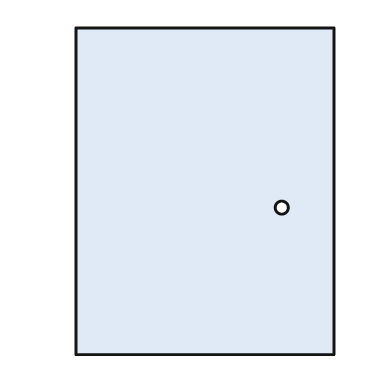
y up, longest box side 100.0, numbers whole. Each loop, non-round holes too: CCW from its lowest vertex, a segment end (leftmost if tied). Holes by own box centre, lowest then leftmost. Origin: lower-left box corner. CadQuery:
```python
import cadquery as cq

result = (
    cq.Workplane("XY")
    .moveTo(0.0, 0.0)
    .lineTo(79.0, 0.0)
    .lineTo(79.0, 100.0)
    .lineTo(0.0, 100.0)
    .close()
    .moveTo(63.0, 45.0)
    .circle(2.0)
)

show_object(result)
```